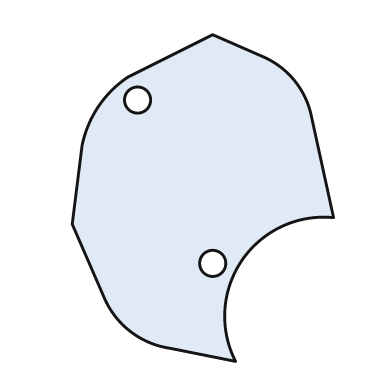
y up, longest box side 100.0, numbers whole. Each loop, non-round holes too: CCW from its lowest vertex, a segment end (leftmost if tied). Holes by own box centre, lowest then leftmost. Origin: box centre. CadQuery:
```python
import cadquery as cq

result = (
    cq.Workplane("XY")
    .moveTo(10.0, -50.0)
    .threePointArc((12.0, -19.0), (40.0, -6.0))
    .lineTo(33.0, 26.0)
    .threePointArc((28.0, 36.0), (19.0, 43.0))
    .lineTo(3.0, 50.0)
    .lineTo(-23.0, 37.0)
    .threePointArc((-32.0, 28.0), (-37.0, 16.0))
    .lineTo(-40.0, -8.0)
    .lineTo(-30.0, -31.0)
    .threePointArc((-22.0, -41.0), (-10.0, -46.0))
    .close()
    .moveTo(3.0, -20.0)
    .circle(4.0)
    .moveTo(-20.0, 30.0)
    .circle(4.0)
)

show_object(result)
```